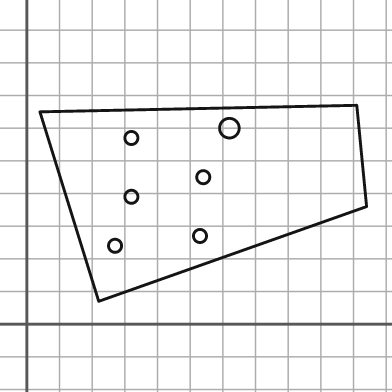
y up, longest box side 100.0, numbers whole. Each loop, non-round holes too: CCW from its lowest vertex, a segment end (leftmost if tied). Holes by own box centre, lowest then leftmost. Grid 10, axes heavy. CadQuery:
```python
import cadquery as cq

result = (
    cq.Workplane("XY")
    .moveTo(22.0, 7.0)
    .lineTo(104.0, 36.0)
    .lineTo(101.0, 67.0)
    .lineTo(4.0, 65.0)
    .close()
    .moveTo(27.0, 24.0)
    .circle(2.0)
    .moveTo(53.0, 27.0)
    .circle(2.0)
    .moveTo(32.0, 39.0)
    .circle(2.0)
    .moveTo(54.0, 45.0)
    .circle(2.0)
    .moveTo(32.0, 57.0)
    .circle(2.0)
    .moveTo(62.0, 60.0)
    .circle(3.0)
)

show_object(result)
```